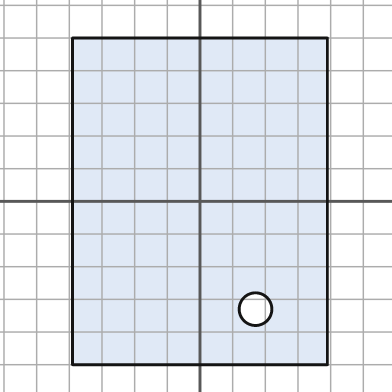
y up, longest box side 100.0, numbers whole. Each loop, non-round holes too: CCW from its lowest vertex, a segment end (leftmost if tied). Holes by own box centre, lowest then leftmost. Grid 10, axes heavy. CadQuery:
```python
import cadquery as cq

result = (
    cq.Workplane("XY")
    .moveTo(-39.0, -50.0)
    .lineTo(39.0, -50.0)
    .lineTo(39.0, 50.0)
    .lineTo(-39.0, 50.0)
    .close()
    .moveTo(17.0, -33.0)
    .circle(5.0)
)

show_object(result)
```